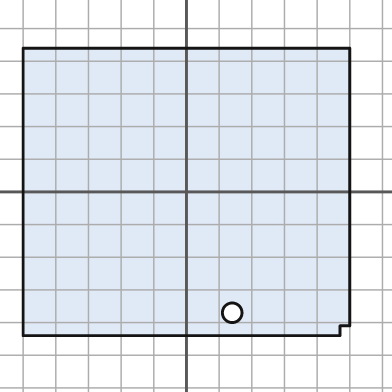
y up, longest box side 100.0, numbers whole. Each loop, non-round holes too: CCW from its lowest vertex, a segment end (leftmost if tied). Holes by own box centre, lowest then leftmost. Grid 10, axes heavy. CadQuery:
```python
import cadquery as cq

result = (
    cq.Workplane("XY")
    .moveTo(-50.0, -44.0)
    .lineTo(47.0, -44.0)
    .lineTo(47.0, -41.0)
    .lineTo(50.0, -41.0)
    .lineTo(50.0, 44.0)
    .lineTo(-50.0, 44.0)
    .close()
    .moveTo(14.0, -37.0)
    .circle(3.0)
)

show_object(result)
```